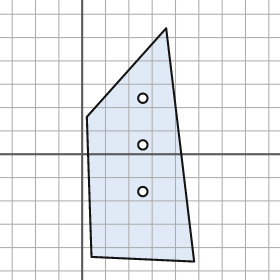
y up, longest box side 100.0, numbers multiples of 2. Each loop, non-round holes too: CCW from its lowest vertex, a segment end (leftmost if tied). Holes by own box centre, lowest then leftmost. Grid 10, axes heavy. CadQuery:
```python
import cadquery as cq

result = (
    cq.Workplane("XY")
    .moveTo(48.0, -46.0)
    .lineTo(36.0, 54.0)
    .lineTo(2.0, 16.0)
    .lineTo(4.0, -44.0)
    .close()
    .moveTo(26.0, -16.0)
    .circle(2.0)
    .moveTo(26.0, 4.0)
    .circle(2.0)
    .moveTo(26.0, 24.0)
    .circle(2.0)
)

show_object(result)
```